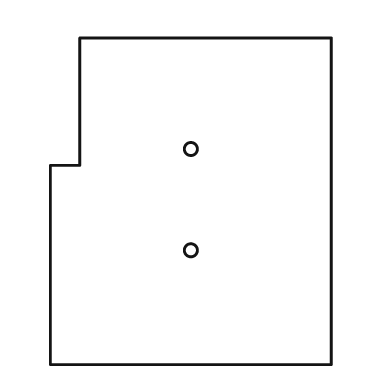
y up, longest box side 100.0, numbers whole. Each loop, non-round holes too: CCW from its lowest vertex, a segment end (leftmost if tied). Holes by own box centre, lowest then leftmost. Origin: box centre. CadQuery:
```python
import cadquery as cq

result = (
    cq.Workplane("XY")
    .moveTo(-43.0, -50.0)
    .lineTo(43.0, -50.0)
    .lineTo(43.0, 50.0)
    .lineTo(-34.0, 50.0)
    .lineTo(-34.0, 11.0)
    .lineTo(-43.0, 11.0)
    .close()
    .moveTo(0.0, -15.0)
    .circle(2.0)
    .moveTo(0.0, 16.0)
    .circle(2.0)
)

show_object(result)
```